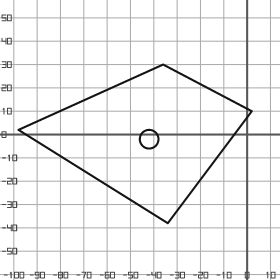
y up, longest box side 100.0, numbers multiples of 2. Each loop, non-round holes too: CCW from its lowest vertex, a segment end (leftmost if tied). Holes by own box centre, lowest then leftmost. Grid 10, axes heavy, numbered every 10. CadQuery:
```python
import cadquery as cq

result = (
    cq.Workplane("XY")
    .moveTo(-34.0, -38.0)
    .lineTo(2.0, 10.0)
    .lineTo(-36.0, 30.0)
    .lineTo(-98.0, 2.0)
    .close()
    .moveTo(-42.0, -2.0)
    .circle(4.0)
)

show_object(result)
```